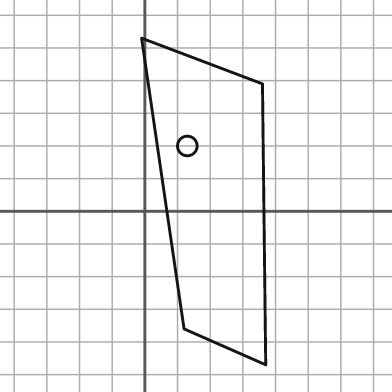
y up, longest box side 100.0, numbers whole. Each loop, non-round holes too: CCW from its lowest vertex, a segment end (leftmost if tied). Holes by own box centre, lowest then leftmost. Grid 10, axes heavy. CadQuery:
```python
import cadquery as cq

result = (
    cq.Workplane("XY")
    .moveTo(37.0, -47.0)
    .lineTo(36.0, 39.0)
    .lineTo(-1.0, 53.0)
    .lineTo(12.0, -36.0)
    .close()
    .moveTo(13.0, 20.0)
    .circle(3.0)
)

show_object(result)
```